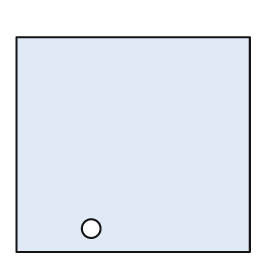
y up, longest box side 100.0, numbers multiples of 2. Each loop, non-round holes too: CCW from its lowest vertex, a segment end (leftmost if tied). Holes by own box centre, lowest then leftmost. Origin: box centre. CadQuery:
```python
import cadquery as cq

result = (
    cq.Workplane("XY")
    .moveTo(-50.0, -46.0)
    .lineTo(50.0, -46.0)
    .lineTo(50.0, 46.0)
    .lineTo(-50.0, 46.0)
    .close()
    .moveTo(-18.0, -36.0)
    .circle(4.0)
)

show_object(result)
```